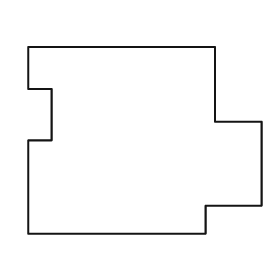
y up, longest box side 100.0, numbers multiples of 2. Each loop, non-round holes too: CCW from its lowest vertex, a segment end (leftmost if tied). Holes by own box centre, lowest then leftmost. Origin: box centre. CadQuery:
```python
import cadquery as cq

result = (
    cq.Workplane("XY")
    .moveTo(-50.0, -40.0)
    .lineTo(26.0, -40.0)
    .lineTo(26.0, -28.0)
    .lineTo(50.0, -28.0)
    .lineTo(50.0, 8.0)
    .lineTo(30.0, 8.0)
    .lineTo(30.0, 40.0)
    .lineTo(-50.0, 40.0)
    .lineTo(-50.0, 22.0)
    .lineTo(-40.0, 22.0)
    .lineTo(-40.0, 0.0)
    .lineTo(-50.0, 0.0)
    .close()
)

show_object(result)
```